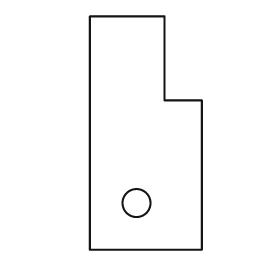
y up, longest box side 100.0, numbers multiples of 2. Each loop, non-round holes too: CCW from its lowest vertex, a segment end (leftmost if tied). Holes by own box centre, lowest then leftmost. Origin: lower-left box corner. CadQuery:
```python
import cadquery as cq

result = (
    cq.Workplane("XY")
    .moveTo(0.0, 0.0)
    .lineTo(48.0, 0.0)
    .lineTo(48.0, 64.0)
    .lineTo(32.0, 64.0)
    .lineTo(32.0, 100.0)
    .lineTo(0.0, 100.0)
    .close()
    .moveTo(20.0, 20.0)
    .circle(6.0)
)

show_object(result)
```